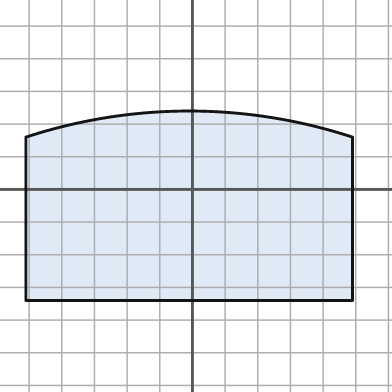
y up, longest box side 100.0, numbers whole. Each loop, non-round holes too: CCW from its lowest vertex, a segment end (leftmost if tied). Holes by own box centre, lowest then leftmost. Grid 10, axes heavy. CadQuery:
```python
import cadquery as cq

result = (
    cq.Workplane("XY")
    .moveTo(-51.0, -34.0)
    .lineTo(49.0, -34.0)
    .lineTo(49.0, 16.0)
    .threePointArc((-1.0, 24.0), (-51.0, 16.0))
    .close()
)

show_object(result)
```